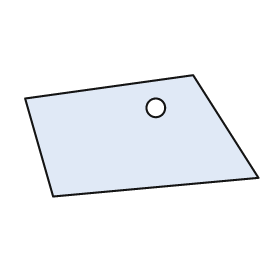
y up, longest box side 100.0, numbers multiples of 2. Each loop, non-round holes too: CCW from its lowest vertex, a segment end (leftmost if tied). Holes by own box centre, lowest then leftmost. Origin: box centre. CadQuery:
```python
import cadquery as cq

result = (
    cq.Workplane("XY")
    .moveTo(-38.0, -26.0)
    .lineTo(50.0, -18.0)
    .lineTo(22.0, 26.0)
    .lineTo(-50.0, 16.0)
    .close()
    .moveTo(6.0, 12.0)
    .circle(4.0)
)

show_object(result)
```